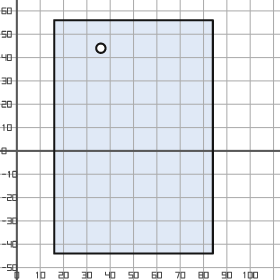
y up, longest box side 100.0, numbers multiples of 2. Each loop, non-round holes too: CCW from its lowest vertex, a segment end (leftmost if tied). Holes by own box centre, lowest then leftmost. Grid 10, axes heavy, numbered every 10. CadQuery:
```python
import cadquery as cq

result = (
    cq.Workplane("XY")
    .moveTo(16.0, -44.0)
    .lineTo(84.0, -44.0)
    .lineTo(84.0, 56.0)
    .lineTo(16.0, 56.0)
    .close()
    .moveTo(36.0, 44.0)
    .circle(2.0)
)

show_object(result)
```